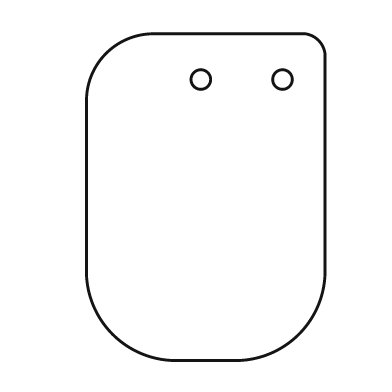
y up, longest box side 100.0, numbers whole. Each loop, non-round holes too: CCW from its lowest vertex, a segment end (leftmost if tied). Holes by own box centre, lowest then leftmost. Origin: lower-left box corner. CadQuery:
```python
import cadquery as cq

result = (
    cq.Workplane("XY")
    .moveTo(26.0, 0.0)
    .lineTo(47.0, 0.0)
    .threePointArc((65.0, 8.0), (73.0, 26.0))
    .lineTo(73.0, 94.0)
    .threePointArc((71.0, 98.0), (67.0, 100.0))
    .lineTo(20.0, 100.0)
    .threePointArc((6.0, 94.0), (0.0, 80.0))
    .lineTo(0.0, 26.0)
    .threePointArc((8.0, 8.0), (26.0, 0.0))
    .close()
    .moveTo(35.0, 86.0)
    .circle(3.0)
    .moveTo(60.0, 86.0)
    .circle(3.0)
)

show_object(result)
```